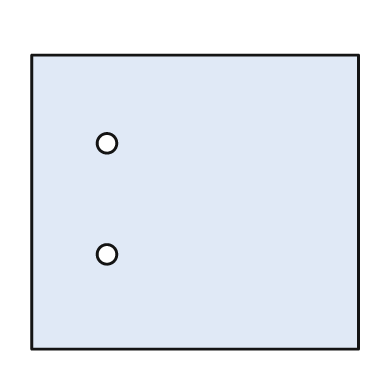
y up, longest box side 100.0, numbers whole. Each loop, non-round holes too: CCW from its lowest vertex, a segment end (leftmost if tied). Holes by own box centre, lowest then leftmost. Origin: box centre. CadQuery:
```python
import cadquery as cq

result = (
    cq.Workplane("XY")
    .moveTo(-50.0, -45.0)
    .lineTo(50.0, -45.0)
    .lineTo(50.0, 45.0)
    .lineTo(-50.0, 45.0)
    .close()
    .moveTo(-27.0, -16.0)
    .circle(3.0)
    .moveTo(-27.0, 18.0)
    .circle(3.0)
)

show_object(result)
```